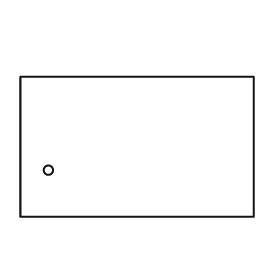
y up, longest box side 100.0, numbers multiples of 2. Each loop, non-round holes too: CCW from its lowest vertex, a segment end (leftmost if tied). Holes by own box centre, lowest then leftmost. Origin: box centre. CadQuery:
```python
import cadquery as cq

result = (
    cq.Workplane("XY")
    .moveTo(-50.0, -30.0)
    .lineTo(50.0, -30.0)
    .lineTo(50.0, 30.0)
    .lineTo(-50.0, 30.0)
    .close()
    .moveTo(-38.0, -10.0)
    .circle(2.0)
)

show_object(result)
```